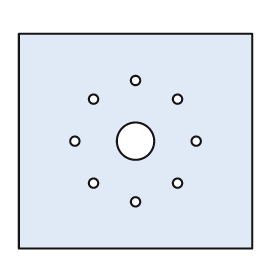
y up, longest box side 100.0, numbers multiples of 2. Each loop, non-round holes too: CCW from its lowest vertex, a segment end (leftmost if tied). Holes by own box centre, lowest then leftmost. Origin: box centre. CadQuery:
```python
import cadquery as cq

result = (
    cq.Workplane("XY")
    .moveTo(-50.0, -46.0)
    .lineTo(50.0, -46.0)
    .lineTo(50.0, 46.0)
    .lineTo(-50.0, 46.0)
    .close()
    .moveTo(0.0, -26.0)
    .circle(2.0)
    .moveTo(-18.0, -18.0)
    .circle(2.0)
    .moveTo(18.0, -18.0)
    .circle(2.0)
    .moveTo(-26.0, 0.0)
    .circle(2.0)
    .moveTo(0.0, 0.0)
    .circle(8.0)
    .moveTo(26.0, 0.0)
    .circle(2.0)
    .moveTo(-18.0, 18.0)
    .circle(2.0)
    .moveTo(18.0, 18.0)
    .circle(2.0)
    .moveTo(0.0, 26.0)
    .circle(2.0)
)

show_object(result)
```